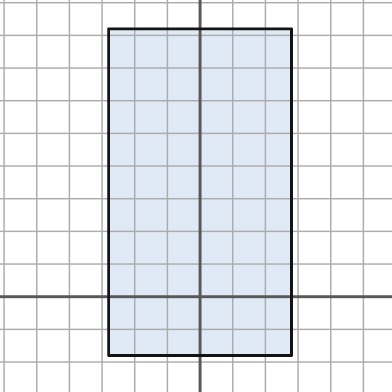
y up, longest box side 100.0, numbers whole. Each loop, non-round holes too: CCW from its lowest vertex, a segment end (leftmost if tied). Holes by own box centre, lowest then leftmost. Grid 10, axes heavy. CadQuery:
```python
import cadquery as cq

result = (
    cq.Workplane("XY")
    .moveTo(-28.0, -18.0)
    .lineTo(28.0, -18.0)
    .lineTo(28.0, 82.0)
    .lineTo(-28.0, 82.0)
    .close()
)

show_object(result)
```